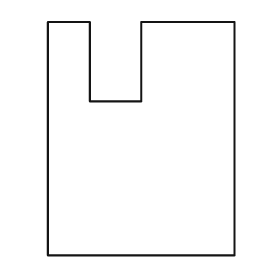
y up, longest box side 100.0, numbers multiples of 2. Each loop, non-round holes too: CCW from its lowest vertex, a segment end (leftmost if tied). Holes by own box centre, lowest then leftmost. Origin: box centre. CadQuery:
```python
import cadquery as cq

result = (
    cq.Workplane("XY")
    .moveTo(-40.0, -50.0)
    .lineTo(40.0, -50.0)
    .lineTo(40.0, 50.0)
    .lineTo(0.0, 50.0)
    .lineTo(0.0, 16.0)
    .lineTo(-22.0, 16.0)
    .lineTo(-22.0, 50.0)
    .lineTo(-40.0, 50.0)
    .close()
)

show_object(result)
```